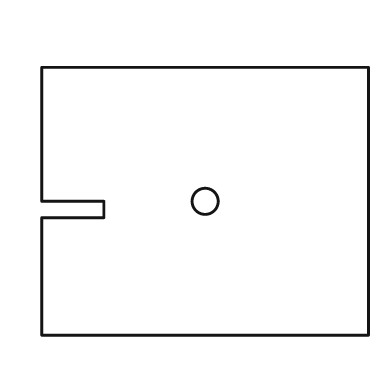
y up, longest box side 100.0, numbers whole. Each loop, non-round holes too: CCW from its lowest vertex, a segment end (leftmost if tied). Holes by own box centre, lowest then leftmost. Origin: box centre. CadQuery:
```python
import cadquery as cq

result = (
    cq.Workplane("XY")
    .moveTo(-50.0, -41.0)
    .lineTo(50.0, -41.0)
    .lineTo(50.0, 41.0)
    .lineTo(-50.0, 41.0)
    .lineTo(-50.0, 0.0)
    .lineTo(-31.0, 0.0)
    .lineTo(-31.0, -5.0)
    .lineTo(-50.0, -5.0)
    .close()
    .moveTo(0.0, 0.0)
    .circle(4.0)
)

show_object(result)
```